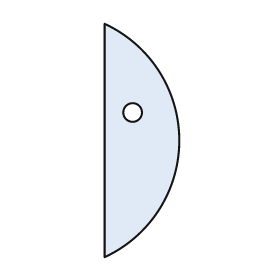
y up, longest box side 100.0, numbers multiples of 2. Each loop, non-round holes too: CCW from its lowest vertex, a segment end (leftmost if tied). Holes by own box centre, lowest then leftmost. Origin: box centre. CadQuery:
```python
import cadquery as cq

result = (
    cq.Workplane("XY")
    .moveTo(-16.0, -50.0)
    .threePointArc((16.0, 0.0), (-16.0, 50.0))
    .close()
    .moveTo(-4.0, 12.0)
    .circle(4.0)
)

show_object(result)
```